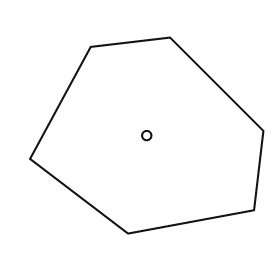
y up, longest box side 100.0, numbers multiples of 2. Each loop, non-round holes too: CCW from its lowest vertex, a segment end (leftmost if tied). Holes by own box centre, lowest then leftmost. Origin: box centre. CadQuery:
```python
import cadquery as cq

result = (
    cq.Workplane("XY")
    .moveTo(-8.0, -42.0)
    .lineTo(46.0, -32.0)
    .lineTo(50.0, 2.0)
    .lineTo(10.0, 42.0)
    .lineTo(-24.0, 38.0)
    .lineTo(-50.0, -10.0)
    .close()
    .moveTo(0.0, 0.0)
    .circle(2.0)
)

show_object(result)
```